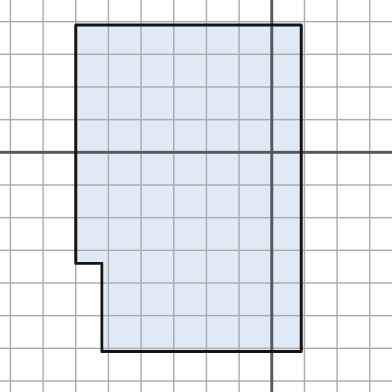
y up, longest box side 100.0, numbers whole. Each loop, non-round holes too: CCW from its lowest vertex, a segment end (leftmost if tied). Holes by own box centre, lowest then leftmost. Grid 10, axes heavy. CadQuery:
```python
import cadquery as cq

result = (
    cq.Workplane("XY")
    .moveTo(-52.0, -61.0)
    .lineTo(9.0, -61.0)
    .lineTo(9.0, 39.0)
    .lineTo(-60.0, 39.0)
    .lineTo(-60.0, -34.0)
    .lineTo(-52.0, -34.0)
    .close()
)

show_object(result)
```